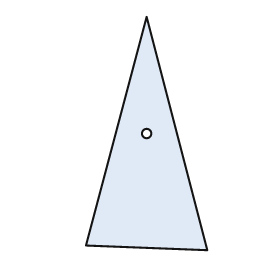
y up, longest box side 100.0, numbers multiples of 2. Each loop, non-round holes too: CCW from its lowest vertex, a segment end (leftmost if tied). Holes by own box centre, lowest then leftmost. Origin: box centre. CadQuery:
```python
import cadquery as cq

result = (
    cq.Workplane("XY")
    .moveTo(26.0, -50.0)
    .lineTo(0.0, 50.0)
    .lineTo(-26.0, -48.0)
    .close()
    .moveTo(0.0, 0.0)
    .circle(2.0)
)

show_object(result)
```